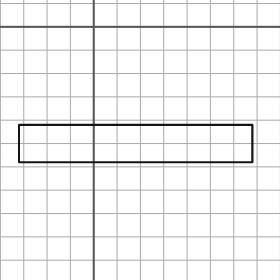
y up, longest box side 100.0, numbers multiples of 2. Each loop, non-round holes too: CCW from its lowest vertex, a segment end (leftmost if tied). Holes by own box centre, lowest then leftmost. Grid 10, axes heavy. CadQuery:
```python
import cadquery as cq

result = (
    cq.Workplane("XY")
    .moveTo(-32.0, -58.0)
    .lineTo(68.0, -58.0)
    .lineTo(68.0, -42.0)
    .lineTo(-32.0, -42.0)
    .close()
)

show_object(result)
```